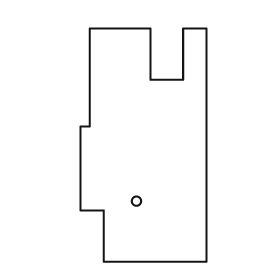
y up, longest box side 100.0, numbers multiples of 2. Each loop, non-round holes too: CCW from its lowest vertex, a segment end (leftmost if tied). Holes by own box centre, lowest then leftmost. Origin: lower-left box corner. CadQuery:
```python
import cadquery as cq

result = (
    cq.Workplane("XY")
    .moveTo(10.0, 0.0)
    .lineTo(54.0, 0.0)
    .lineTo(54.0, 100.0)
    .lineTo(44.0, 100.0)
    .lineTo(44.0, 78.0)
    .lineTo(30.0, 78.0)
    .lineTo(30.0, 100.0)
    .lineTo(4.0, 100.0)
    .lineTo(4.0, 58.0)
    .lineTo(0.0, 58.0)
    .lineTo(0.0, 22.0)
    .lineTo(10.0, 22.0)
    .close()
    .moveTo(24.0, 26.0)
    .circle(2.0)
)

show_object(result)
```